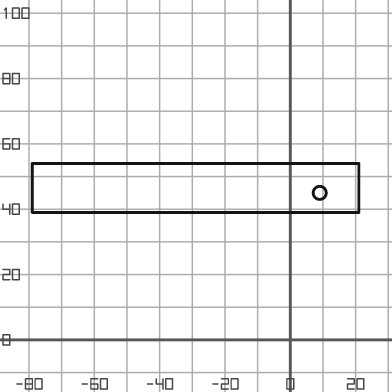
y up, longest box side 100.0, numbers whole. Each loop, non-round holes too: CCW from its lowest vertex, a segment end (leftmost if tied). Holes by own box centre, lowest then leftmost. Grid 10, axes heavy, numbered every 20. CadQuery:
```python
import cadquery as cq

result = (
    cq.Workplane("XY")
    .moveTo(-79.0, 39.0)
    .lineTo(21.0, 39.0)
    .lineTo(21.0, 54.0)
    .lineTo(-79.0, 54.0)
    .close()
    .moveTo(9.0, 45.0)
    .circle(2.0)
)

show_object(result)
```